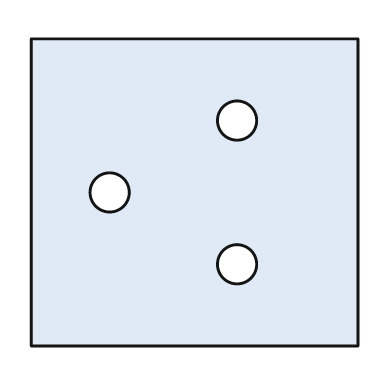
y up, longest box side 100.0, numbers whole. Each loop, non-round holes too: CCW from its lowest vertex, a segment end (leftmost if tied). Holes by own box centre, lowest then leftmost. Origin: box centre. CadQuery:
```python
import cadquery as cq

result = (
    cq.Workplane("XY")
    .moveTo(-50.0, -47.0)
    .lineTo(50.0, -47.0)
    .lineTo(50.0, 47.0)
    .lineTo(-50.0, 47.0)
    .close()
    .moveTo(13.0, -22.0)
    .circle(6.0)
    .moveTo(-26.0, 0.0)
    .circle(6.0)
    .moveTo(13.0, 22.0)
    .circle(6.0)
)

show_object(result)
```